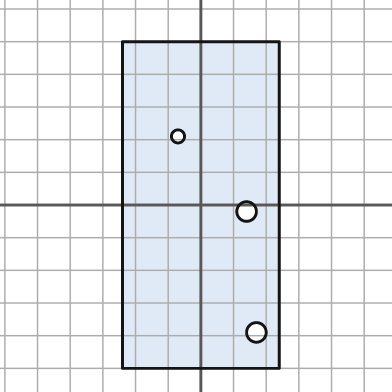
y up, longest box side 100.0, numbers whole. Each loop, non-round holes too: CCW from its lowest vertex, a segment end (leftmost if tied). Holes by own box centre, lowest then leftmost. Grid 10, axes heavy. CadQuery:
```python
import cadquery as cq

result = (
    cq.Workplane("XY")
    .moveTo(-24.0, -50.0)
    .lineTo(24.0, -50.0)
    .lineTo(24.0, 50.0)
    .lineTo(-24.0, 50.0)
    .close()
    .moveTo(17.0, -39.0)
    .circle(3.0)
    .moveTo(14.0, -2.0)
    .circle(3.0)
    .moveTo(-7.0, 21.0)
    .circle(2.0)
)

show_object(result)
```